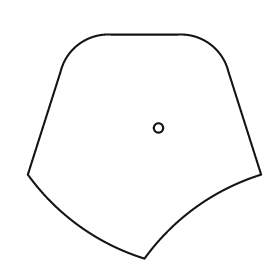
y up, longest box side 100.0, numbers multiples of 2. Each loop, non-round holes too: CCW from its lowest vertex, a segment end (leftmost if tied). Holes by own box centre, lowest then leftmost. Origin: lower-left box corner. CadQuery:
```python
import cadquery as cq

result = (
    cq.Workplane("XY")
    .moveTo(50.0, 0.0)
    .threePointArc((72.0, 22.0), (100.0, 36.0))
    .lineTo(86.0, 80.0)
    .threePointArc((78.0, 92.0), (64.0, 96.0))
    .lineTo(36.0, 96.0)
    .threePointArc((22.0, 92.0), (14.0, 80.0))
    .lineTo(0.0, 36.0)
    .threePointArc((22.0, 14.0), (50.0, 0.0))
    .close()
    .moveTo(56.0, 56.0)
    .circle(2.0)
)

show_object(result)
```